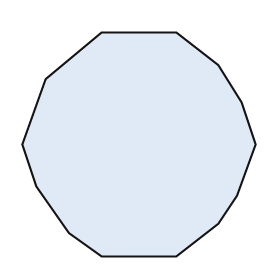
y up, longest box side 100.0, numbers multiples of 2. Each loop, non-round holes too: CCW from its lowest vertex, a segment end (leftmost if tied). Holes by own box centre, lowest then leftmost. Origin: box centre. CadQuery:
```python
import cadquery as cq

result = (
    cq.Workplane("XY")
    .moveTo(-16.0, -48.0)
    .lineTo(16.0, -48.0)
    .lineTo(34.0, -34.0)
    .lineTo(42.0, -22.0)
    .lineTo(50.0, 0.0)
    .lineTo(44.0, 18.0)
    .lineTo(34.0, 34.0)
    .lineTo(16.0, 48.0)
    .lineTo(-16.0, 48.0)
    .lineTo(-40.0, 28.0)
    .lineTo(-50.0, 0.0)
    .lineTo(-44.0, -18.0)
    .lineTo(-30.0, -38.0)
    .close()
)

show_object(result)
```